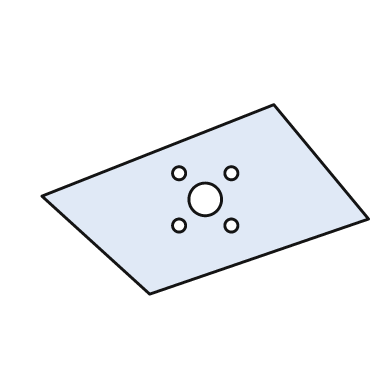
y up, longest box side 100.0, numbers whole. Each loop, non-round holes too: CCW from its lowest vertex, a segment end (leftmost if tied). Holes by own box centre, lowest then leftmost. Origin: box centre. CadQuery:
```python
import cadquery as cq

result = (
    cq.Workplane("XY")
    .moveTo(-17.0, -29.0)
    .lineTo(50.0, -6.0)
    .lineTo(21.0, 29.0)
    .lineTo(-50.0, 1.0)
    .close()
    .moveTo(-8.0, -8.0)
    .circle(2.0)
    .moveTo(8.0, -8.0)
    .circle(2.0)
    .moveTo(0.0, 0.0)
    .circle(5.0)
    .moveTo(-8.0, 8.0)
    .circle(2.0)
    .moveTo(8.0, 8.0)
    .circle(2.0)
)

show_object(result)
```